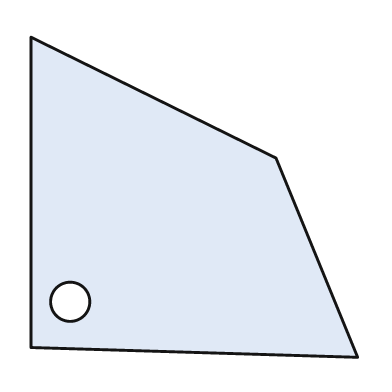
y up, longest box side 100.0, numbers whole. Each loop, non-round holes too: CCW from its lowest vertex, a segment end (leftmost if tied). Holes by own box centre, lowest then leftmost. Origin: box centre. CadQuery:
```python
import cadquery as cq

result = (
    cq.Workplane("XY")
    .moveTo(50.0, -49.0)
    .lineTo(25.0, 12.0)
    .lineTo(-50.0, 49.0)
    .lineTo(-50.0, -46.0)
    .close()
    .moveTo(-38.0, -32.0)
    .circle(6.0)
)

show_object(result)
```